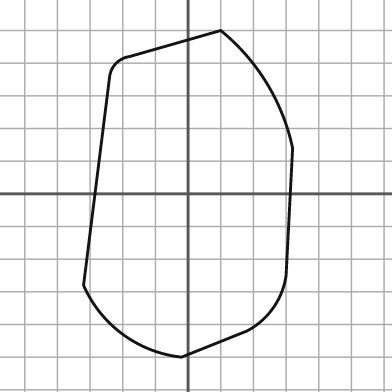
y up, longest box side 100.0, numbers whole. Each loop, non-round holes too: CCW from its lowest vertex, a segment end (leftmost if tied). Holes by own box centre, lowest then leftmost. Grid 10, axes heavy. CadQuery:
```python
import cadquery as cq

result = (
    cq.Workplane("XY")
    .moveTo(-2.0, -50.0)
    .lineTo(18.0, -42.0)
    .threePointArc((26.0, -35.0), (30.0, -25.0))
    .lineTo(32.0, 14.0)
    .threePointArc((24.0, 34.0), (10.0, 50.0))
    .lineTo(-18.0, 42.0)
    .threePointArc((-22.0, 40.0), (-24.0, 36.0))
    .lineTo(-32.0, -28.0)
    .threePointArc((-20.0, -43.0), (-2.0, -50.0))
    .close()
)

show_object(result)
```